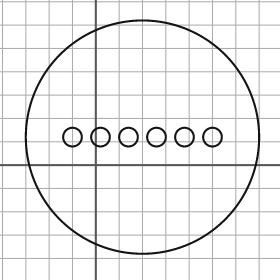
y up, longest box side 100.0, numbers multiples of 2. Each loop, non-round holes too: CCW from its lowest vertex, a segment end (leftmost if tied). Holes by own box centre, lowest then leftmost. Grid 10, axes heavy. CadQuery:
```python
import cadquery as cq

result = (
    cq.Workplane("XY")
    .moveTo(20.0, 12.0)
    .circle(50.0)
    .moveTo(-10.0, 12.0)
    .circle(4.0)
    .moveTo(2.0, 12.0)
    .circle(4.0)
    .moveTo(14.0, 12.0)
    .circle(4.0)
    .moveTo(26.0, 12.0)
    .circle(4.0)
    .moveTo(38.0, 12.0)
    .circle(4.0)
    .moveTo(50.0, 12.0)
    .circle(4.0)
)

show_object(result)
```